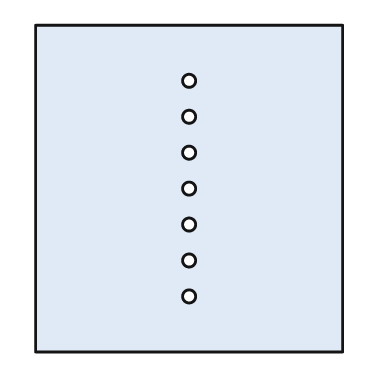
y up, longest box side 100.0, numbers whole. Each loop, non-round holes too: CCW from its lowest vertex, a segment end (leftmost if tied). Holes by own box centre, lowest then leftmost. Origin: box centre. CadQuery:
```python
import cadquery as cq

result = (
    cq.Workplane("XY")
    .moveTo(-47.0, -50.0)
    .lineTo(47.0, -50.0)
    .lineTo(47.0, 50.0)
    .lineTo(-47.0, 50.0)
    .close()
    .moveTo(0.0, -33.0)
    .circle(2.0)
    .moveTo(0.0, -22.0)
    .circle(2.0)
    .moveTo(0.0, -11.0)
    .circle(2.0)
    .moveTo(0.0, 0.0)
    .circle(2.0)
    .moveTo(0.0, 11.0)
    .circle(2.0)
    .moveTo(0.0, 22.0)
    .circle(2.0)
    .moveTo(0.0, 33.0)
    .circle(2.0)
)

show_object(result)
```